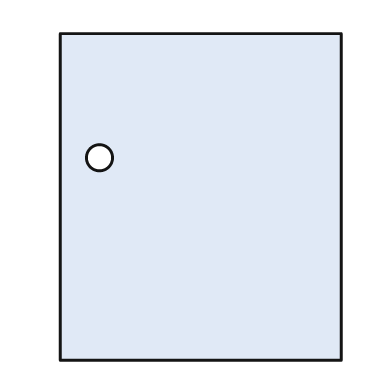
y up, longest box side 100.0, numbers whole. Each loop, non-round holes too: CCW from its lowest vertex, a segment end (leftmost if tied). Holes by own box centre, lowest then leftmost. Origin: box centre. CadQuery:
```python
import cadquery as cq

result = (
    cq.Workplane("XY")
    .moveTo(-43.0, -50.0)
    .lineTo(43.0, -50.0)
    .lineTo(43.0, 50.0)
    .lineTo(-43.0, 50.0)
    .close()
    .moveTo(-31.0, 12.0)
    .circle(4.0)
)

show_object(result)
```